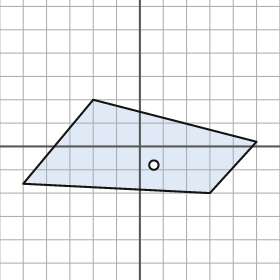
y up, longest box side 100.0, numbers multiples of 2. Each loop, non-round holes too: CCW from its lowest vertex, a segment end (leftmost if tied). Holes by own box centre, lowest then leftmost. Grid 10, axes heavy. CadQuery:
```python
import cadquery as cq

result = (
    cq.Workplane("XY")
    .moveTo(30.0, -20.0)
    .lineTo(50.0, 2.0)
    .lineTo(-20.0, 20.0)
    .lineTo(-50.0, -16.0)
    .close()
    .moveTo(6.0, -8.0)
    .circle(2.0)
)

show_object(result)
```